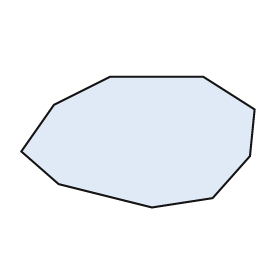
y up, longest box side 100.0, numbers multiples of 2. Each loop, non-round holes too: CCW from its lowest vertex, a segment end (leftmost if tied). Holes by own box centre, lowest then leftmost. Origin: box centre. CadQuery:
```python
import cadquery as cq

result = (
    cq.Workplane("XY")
    .moveTo(6.0, -28.0)
    .lineTo(32.0, -24.0)
    .lineTo(48.0, -6.0)
    .lineTo(50.0, 14.0)
    .lineTo(28.0, 28.0)
    .lineTo(-12.0, 28.0)
    .lineTo(-36.0, 16.0)
    .lineTo(-50.0, -4.0)
    .lineTo(-34.0, -18.0)
    .close()
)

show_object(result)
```